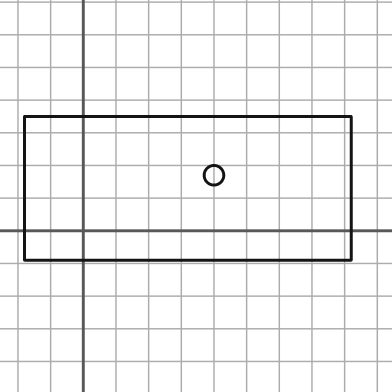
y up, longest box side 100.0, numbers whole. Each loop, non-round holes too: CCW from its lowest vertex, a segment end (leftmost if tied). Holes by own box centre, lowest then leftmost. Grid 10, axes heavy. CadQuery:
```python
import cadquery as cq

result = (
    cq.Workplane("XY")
    .moveTo(-18.0, -9.0)
    .lineTo(82.0, -9.0)
    .lineTo(82.0, 35.0)
    .lineTo(-18.0, 35.0)
    .close()
    .moveTo(40.0, 17.0)
    .circle(3.0)
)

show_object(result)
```